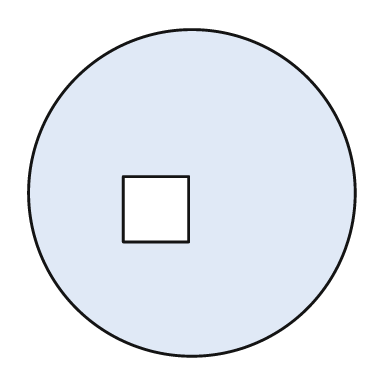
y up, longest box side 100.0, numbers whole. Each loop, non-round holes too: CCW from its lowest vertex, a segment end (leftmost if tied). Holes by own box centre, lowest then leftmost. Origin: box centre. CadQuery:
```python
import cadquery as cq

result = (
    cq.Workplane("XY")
    .moveTo(0.0, 0.0)
    .circle(50.0)
    .moveTo(-21.0, -15.0)
    .lineTo(-1.0, -15.0)
    .lineTo(-1.0, 5.0)
    .lineTo(-21.0, 5.0)
    .close()
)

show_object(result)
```